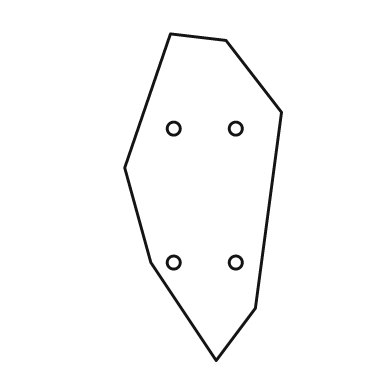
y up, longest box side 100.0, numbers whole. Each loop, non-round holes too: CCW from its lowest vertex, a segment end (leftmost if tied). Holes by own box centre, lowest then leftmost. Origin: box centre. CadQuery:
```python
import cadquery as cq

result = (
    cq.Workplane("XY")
    .moveTo(4.0, -50.0)
    .lineTo(16.0, -34.0)
    .lineTo(24.0, 26.0)
    .lineTo(7.0, 48.0)
    .lineTo(-10.0, 50.0)
    .lineTo(-24.0, 9.0)
    .lineTo(-16.0, -20.0)
    .close()
    .moveTo(-9.0, -20.0)
    .circle(2.0)
    .moveTo(10.0, -20.0)
    .circle(2.0)
    .moveTo(-9.0, 21.0)
    .circle(2.0)
    .moveTo(10.0, 21.0)
    .circle(2.0)
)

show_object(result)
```